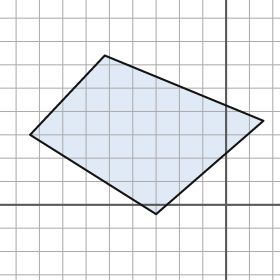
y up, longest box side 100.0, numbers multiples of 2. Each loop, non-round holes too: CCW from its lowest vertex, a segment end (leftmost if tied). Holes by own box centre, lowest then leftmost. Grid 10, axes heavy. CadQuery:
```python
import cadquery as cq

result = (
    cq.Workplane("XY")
    .moveTo(-30.0, -4.0)
    .lineTo(16.0, 36.0)
    .lineTo(-52.0, 64.0)
    .lineTo(-84.0, 30.0)
    .close()
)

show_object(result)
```